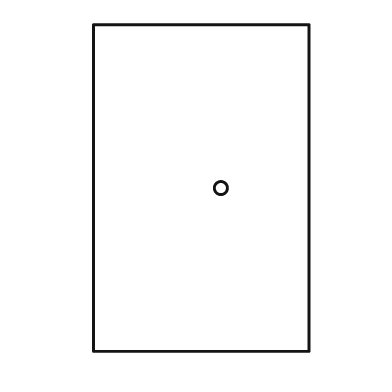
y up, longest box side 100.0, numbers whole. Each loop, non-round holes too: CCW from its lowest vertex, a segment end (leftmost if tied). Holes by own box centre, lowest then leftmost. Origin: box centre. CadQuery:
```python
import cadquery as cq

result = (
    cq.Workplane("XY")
    .moveTo(-33.0, -50.0)
    .lineTo(33.0, -50.0)
    .lineTo(33.0, 50.0)
    .lineTo(-33.0, 50.0)
    .close()
    .moveTo(6.0, 0.0)
    .circle(2.0)
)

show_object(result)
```